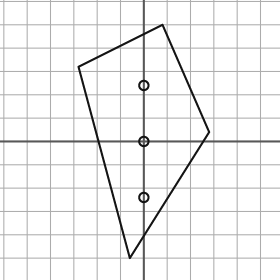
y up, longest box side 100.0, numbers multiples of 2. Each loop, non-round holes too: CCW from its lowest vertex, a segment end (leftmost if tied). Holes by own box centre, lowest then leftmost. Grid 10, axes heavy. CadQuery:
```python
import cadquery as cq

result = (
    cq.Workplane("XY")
    .moveTo(-6.0, -50.0)
    .lineTo(28.0, 4.0)
    .lineTo(8.0, 50.0)
    .lineTo(-28.0, 32.0)
    .close()
    .moveTo(0.0, -24.0)
    .circle(2.0)
    .moveTo(0.0, 0.0)
    .circle(2.0)
    .moveTo(0.0, 24.0)
    .circle(2.0)
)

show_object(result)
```